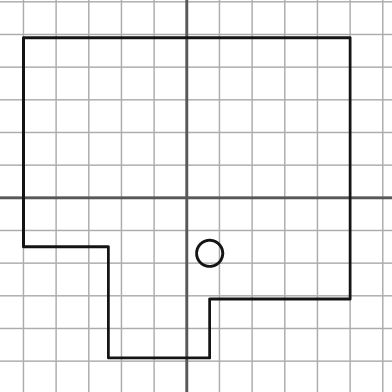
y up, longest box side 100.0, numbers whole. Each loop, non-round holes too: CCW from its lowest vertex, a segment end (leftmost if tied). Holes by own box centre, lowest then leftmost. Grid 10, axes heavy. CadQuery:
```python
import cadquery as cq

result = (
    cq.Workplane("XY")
    .moveTo(-24.0, -49.0)
    .lineTo(7.0, -49.0)
    .lineTo(7.0, -31.0)
    .lineTo(50.0, -31.0)
    .lineTo(50.0, 49.0)
    .lineTo(-50.0, 49.0)
    .lineTo(-50.0, -15.0)
    .lineTo(-24.0, -15.0)
    .close()
    .moveTo(7.0, -17.0)
    .circle(4.0)
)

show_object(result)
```